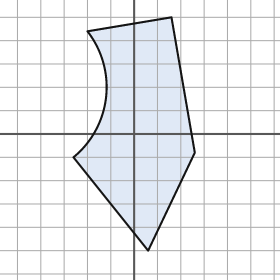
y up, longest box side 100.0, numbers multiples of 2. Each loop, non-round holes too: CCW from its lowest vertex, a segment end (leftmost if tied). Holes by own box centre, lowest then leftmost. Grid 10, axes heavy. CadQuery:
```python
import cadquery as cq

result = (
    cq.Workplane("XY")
    .moveTo(6.0, -50.0)
    .lineTo(26.0, -8.0)
    .lineTo(16.0, 50.0)
    .lineTo(-20.0, 44.0)
    .threePointArc((-12.0, 16.0), (-26.0, -10.0))
    .close()
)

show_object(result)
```